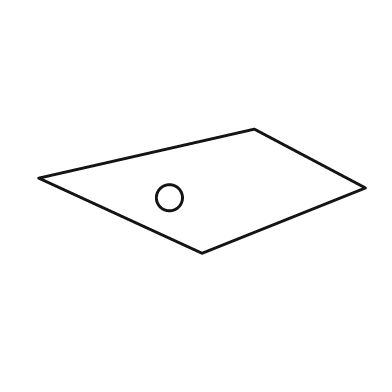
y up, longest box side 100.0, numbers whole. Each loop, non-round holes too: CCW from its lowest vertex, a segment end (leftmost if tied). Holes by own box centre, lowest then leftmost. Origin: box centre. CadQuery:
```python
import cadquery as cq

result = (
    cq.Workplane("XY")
    .moveTo(0.0, -19.0)
    .lineTo(50.0, 1.0)
    .lineTo(16.0, 19.0)
    .lineTo(-50.0, 4.0)
    .close()
    .moveTo(-10.0, -2.0)
    .circle(4.0)
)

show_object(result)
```